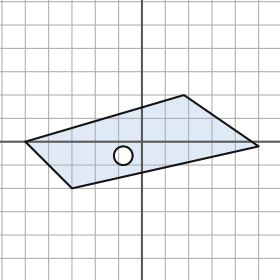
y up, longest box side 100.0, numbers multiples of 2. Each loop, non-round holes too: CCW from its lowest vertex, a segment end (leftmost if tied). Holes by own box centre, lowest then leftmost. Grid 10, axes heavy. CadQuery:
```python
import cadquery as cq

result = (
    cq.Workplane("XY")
    .moveTo(-30.0, -20.0)
    .lineTo(50.0, -2.0)
    .lineTo(18.0, 20.0)
    .lineTo(-50.0, 0.0)
    .close()
    .moveTo(-8.0, -6.0)
    .circle(4.0)
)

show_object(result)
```